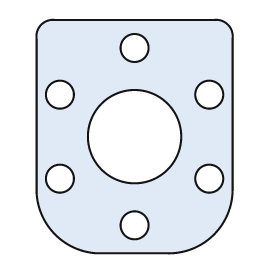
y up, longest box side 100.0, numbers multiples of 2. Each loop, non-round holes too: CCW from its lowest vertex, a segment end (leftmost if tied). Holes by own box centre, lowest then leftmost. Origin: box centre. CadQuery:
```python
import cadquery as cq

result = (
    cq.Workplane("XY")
    .moveTo(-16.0, -50.0)
    .lineTo(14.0, -50.0)
    .threePointArc((34.0, -42.0), (42.0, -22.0))
    .lineTo(42.0, 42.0)
    .threePointArc((40.0, 48.0), (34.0, 50.0))
    .lineTo(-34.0, 50.0)
    .threePointArc((-40.0, 48.0), (-42.0, 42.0))
    .lineTo(-42.0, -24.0)
    .threePointArc((-34.0, -42.0), (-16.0, -50.0))
    .close()
    .moveTo(0.0, -38.0)
    .circle(6.0)
    .moveTo(-32.0, -18.0)
    .circle(6.0)
    .moveTo(32.0, -18.0)
    .circle(6.0)
    .moveTo(0.0, 0.0)
    .circle(20.0)
    .moveTo(-32.0, 18.0)
    .circle(6.0)
    .moveTo(32.0, 18.0)
    .circle(6.0)
    .moveTo(0.0, 38.0)
    .circle(6.0)
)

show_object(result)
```